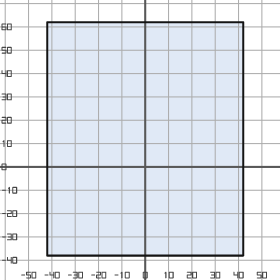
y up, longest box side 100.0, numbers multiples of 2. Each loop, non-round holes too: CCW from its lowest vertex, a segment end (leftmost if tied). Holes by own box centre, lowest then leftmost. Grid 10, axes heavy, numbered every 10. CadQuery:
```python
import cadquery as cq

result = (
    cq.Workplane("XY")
    .moveTo(-42.0, -38.0)
    .lineTo(42.0, -38.0)
    .lineTo(42.0, 62.0)
    .lineTo(-42.0, 62.0)
    .close()
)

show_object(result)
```